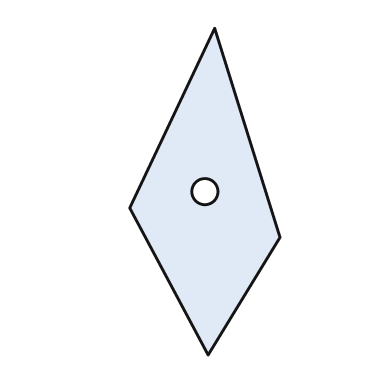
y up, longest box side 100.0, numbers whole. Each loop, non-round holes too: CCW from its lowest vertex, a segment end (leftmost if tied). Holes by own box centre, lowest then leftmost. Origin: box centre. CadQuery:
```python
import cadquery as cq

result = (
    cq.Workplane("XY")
    .moveTo(1.0, -50.0)
    .lineTo(23.0, -14.0)
    .lineTo(3.0, 50.0)
    .lineTo(-23.0, -5.0)
    .close()
    .moveTo(0.0, 0.0)
    .circle(4.0)
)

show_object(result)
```